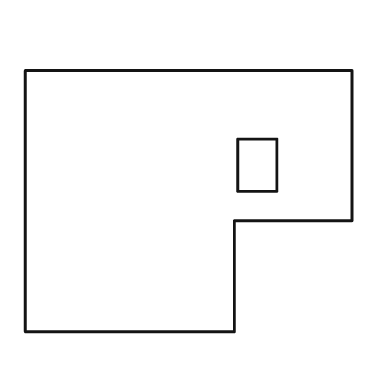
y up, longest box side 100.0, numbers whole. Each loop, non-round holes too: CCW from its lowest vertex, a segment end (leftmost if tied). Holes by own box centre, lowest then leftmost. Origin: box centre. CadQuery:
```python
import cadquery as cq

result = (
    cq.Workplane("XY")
    .moveTo(-50.0, -40.0)
    .lineTo(14.0, -40.0)
    .lineTo(14.0, -6.0)
    .lineTo(50.0, -6.0)
    .lineTo(50.0, 40.0)
    .lineTo(-50.0, 40.0)
    .close()
    .moveTo(15.0, 3.0)
    .lineTo(27.0, 3.0)
    .lineTo(27.0, 19.0)
    .lineTo(15.0, 19.0)
    .close()
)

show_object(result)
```